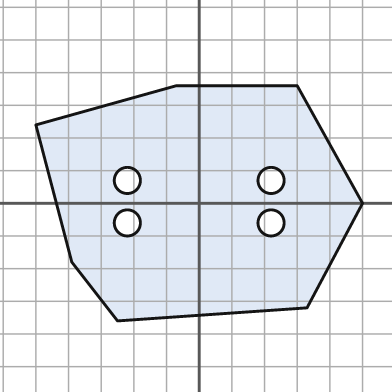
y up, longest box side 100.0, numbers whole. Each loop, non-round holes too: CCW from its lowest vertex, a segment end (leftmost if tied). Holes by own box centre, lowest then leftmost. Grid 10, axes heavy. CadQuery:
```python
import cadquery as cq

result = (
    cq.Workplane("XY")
    .moveTo(-25.0, -36.0)
    .lineTo(33.0, -32.0)
    .lineTo(50.0, 0.0)
    .lineTo(30.0, 36.0)
    .lineTo(-7.0, 36.0)
    .lineTo(-50.0, 24.0)
    .lineTo(-39.0, -18.0)
    .close()
    .moveTo(-22.0, -6.0)
    .circle(4.0)
    .moveTo(22.0, -6.0)
    .circle(4.0)
    .moveTo(-22.0, 7.0)
    .circle(4.0)
    .moveTo(22.0, 7.0)
    .circle(4.0)
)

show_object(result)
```